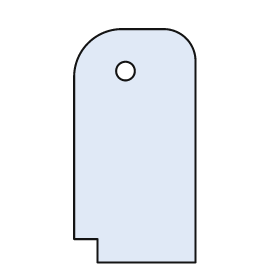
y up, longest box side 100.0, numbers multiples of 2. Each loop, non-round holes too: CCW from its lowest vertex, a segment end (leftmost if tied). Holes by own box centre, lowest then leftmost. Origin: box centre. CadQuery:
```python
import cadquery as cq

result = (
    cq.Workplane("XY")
    .moveTo(-16.0, -50.0)
    .lineTo(26.0, -50.0)
    .lineTo(26.0, 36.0)
    .threePointArc((22.0, 46.0), (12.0, 50.0))
    .lineTo(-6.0, 50.0)
    .threePointArc((-20.0, 44.0), (-26.0, 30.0))
    .lineTo(-26.0, -40.0)
    .lineTo(-16.0, -40.0)
    .close()
    .moveTo(-4.0, 32.0)
    .circle(4.0)
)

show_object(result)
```